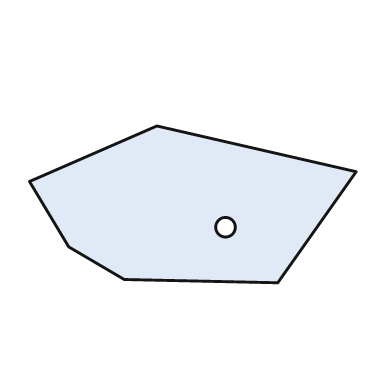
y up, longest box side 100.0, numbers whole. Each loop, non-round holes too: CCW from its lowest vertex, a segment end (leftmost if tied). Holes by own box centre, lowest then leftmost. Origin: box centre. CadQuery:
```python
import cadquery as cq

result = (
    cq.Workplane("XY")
    .moveTo(26.0, -24.0)
    .lineTo(50.0, 10.0)
    .lineTo(-11.0, 24.0)
    .lineTo(-50.0, 7.0)
    .lineTo(-38.0, -13.0)
    .lineTo(-21.0, -23.0)
    .close()
    .moveTo(10.0, -7.0)
    .circle(3.0)
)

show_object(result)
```